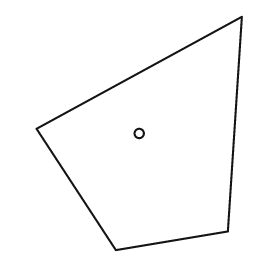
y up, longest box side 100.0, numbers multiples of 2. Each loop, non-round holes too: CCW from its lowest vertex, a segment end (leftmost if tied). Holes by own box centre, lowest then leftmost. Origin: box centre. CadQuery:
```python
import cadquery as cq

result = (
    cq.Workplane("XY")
    .moveTo(-10.0, -50.0)
    .lineTo(38.0, -42.0)
    .lineTo(44.0, 50.0)
    .lineTo(-44.0, 2.0)
    .close()
    .moveTo(0.0, 0.0)
    .circle(2.0)
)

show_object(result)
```